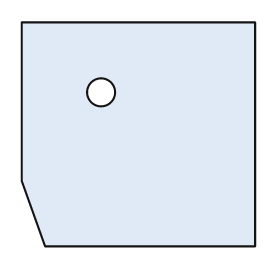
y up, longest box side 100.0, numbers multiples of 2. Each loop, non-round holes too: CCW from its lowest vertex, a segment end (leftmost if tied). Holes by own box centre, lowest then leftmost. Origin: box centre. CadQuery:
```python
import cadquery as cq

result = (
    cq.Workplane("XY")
    .moveTo(-40.0, -48.0)
    .lineTo(50.0, -48.0)
    .lineTo(50.0, 48.0)
    .lineTo(-50.0, 48.0)
    .lineTo(-50.0, -20.0)
    .close()
    .moveTo(-16.0, 18.0)
    .circle(6.0)
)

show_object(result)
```